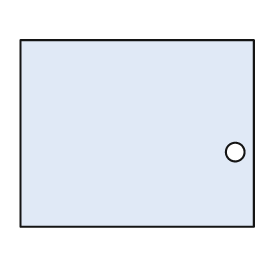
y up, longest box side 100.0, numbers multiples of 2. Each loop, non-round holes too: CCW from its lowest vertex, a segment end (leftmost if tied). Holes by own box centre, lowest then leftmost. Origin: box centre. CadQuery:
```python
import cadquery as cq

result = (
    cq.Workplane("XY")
    .moveTo(-50.0, -40.0)
    .lineTo(50.0, -40.0)
    .lineTo(50.0, 40.0)
    .lineTo(-50.0, 40.0)
    .close()
    .moveTo(42.0, -8.0)
    .circle(4.0)
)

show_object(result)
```